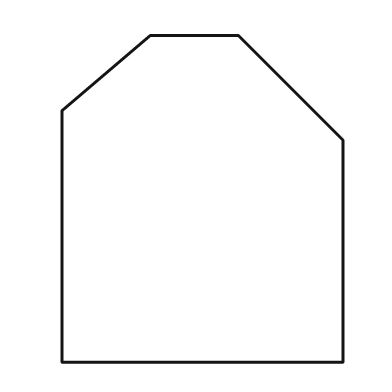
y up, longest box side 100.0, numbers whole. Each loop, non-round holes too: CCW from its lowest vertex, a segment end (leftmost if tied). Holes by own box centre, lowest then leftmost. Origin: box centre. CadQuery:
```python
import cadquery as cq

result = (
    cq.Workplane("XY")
    .moveTo(-43.0, -50.0)
    .lineTo(43.0, -50.0)
    .lineTo(43.0, 18.0)
    .lineTo(11.0, 50.0)
    .lineTo(-16.0, 50.0)
    .lineTo(-43.0, 27.0)
    .close()
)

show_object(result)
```